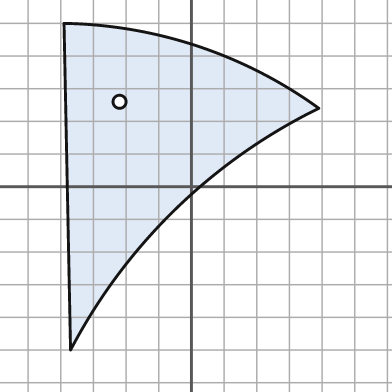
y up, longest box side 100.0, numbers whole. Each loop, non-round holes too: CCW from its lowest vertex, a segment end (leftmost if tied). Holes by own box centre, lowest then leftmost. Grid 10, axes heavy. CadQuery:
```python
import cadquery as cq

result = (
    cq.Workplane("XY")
    .moveTo(-37.0, -50.0)
    .threePointArc((-5.0, -7.0), (39.0, 24.0))
    .threePointArc((2.0, 43.0), (-39.0, 50.0))
    .close()
    .moveTo(-22.0, 26.0)
    .circle(2.0)
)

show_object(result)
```